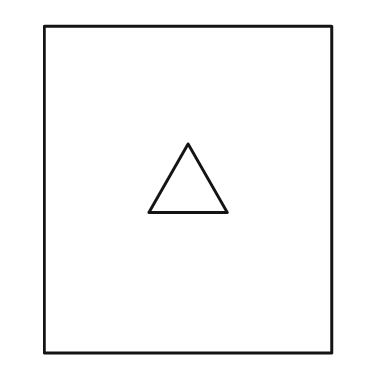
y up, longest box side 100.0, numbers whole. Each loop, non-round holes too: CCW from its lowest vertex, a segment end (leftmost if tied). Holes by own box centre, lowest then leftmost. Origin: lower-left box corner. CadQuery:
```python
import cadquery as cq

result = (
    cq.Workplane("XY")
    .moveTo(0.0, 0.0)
    .lineTo(88.0, 0.0)
    .lineTo(88.0, 100.0)
    .lineTo(0.0, 100.0)
    .close()
    .moveTo(32.0, 43.0)
    .lineTo(56.0, 43.0)
    .lineTo(44.0, 64.0)
    .close()
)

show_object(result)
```